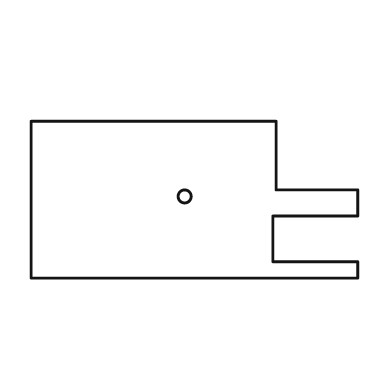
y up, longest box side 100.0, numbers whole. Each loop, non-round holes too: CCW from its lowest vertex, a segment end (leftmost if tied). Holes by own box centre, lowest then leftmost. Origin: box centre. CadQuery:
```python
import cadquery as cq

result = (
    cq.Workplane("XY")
    .moveTo(-50.0, -24.0)
    .lineTo(50.0, -24.0)
    .lineTo(50.0, -19.0)
    .lineTo(24.0, -19.0)
    .lineTo(24.0, -5.0)
    .lineTo(50.0, -5.0)
    .lineTo(50.0, 3.0)
    .lineTo(25.0, 3.0)
    .lineTo(25.0, 24.0)
    .lineTo(-50.0, 24.0)
    .close()
    .moveTo(-3.0, 1.0)
    .circle(2.0)
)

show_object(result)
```